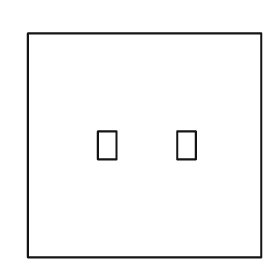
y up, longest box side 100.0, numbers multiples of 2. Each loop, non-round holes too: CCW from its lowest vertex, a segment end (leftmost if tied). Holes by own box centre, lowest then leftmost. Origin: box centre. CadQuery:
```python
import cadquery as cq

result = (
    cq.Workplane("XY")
    .moveTo(-50.0, -48.0)
    .lineTo(50.0, -48.0)
    .lineTo(50.0, 48.0)
    .lineTo(-50.0, 48.0)
    .close()
    .moveTo(-20.0, -6.0)
    .lineTo(-12.0, -6.0)
    .lineTo(-12.0, 6.0)
    .lineTo(-20.0, 6.0)
    .close()
    .moveTo(14.0, -6.0)
    .lineTo(22.0, -6.0)
    .lineTo(22.0, 6.0)
    .lineTo(14.0, 6.0)
    .close()
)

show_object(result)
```